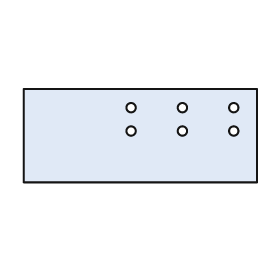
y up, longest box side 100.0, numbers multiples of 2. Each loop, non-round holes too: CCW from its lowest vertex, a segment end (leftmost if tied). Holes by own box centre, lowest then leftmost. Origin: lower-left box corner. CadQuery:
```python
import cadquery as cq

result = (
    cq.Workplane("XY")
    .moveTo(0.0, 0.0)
    .lineTo(100.0, 0.0)
    .lineTo(100.0, 40.0)
    .lineTo(0.0, 40.0)
    .close()
    .moveTo(46.0, 22.0)
    .circle(2.0)
    .moveTo(68.0, 22.0)
    .circle(2.0)
    .moveTo(90.0, 22.0)
    .circle(2.0)
    .moveTo(46.0, 32.0)
    .circle(2.0)
    .moveTo(68.0, 32.0)
    .circle(2.0)
    .moveTo(90.0, 32.0)
    .circle(2.0)
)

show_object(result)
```